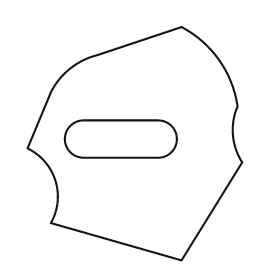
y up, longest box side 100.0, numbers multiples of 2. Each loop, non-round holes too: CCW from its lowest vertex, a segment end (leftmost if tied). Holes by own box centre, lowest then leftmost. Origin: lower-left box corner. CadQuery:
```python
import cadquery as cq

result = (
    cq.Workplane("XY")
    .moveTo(66.0, 0.0)
    .lineTo(92.0, 42.0)
    .threePointArc((88.0, 54.0), (90.0, 66.0))
    .threePointArc((82.0, 86.0), (66.0, 100.0))
    .lineTo(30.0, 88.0)
    .threePointArc((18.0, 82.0), (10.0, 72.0))
    .lineTo(0.0, 48.0)
    .threePointArc((12.0, 34.0), (10.0, 16.0))
    .close()
    .moveTo(24.0, 44.0)
    .lineTo(56.0, 44.0)
    .threePointArc((64.0, 52.0), (56.0, 60.0))
    .lineTo(24.0, 60.0)
    .threePointArc((16.0, 52.0), (24.0, 44.0))
    .close()
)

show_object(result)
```